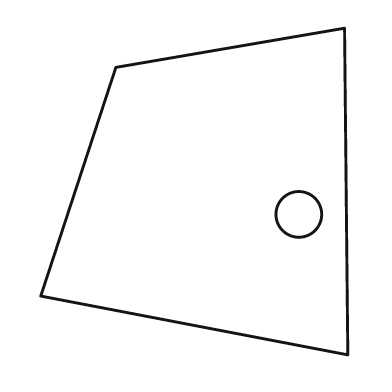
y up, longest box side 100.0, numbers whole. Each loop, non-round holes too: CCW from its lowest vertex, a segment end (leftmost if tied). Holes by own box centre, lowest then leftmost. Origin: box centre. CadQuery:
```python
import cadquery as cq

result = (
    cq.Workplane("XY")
    .moveTo(47.0, -50.0)
    .lineTo(46.0, 50.0)
    .lineTo(-24.0, 38.0)
    .lineTo(-47.0, -32.0)
    .close()
    .moveTo(32.0, -7.0)
    .circle(7.0)
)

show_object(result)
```